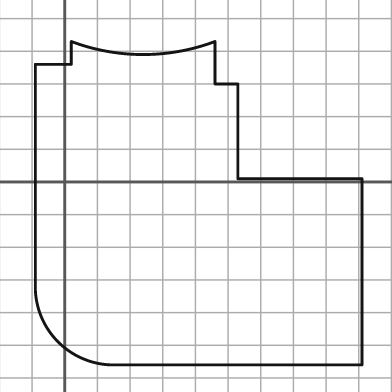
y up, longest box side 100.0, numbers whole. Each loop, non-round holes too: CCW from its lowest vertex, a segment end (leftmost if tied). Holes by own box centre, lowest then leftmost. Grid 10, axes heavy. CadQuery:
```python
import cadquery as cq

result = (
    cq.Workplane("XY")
    .moveTo(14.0, -56.0)
    .lineTo(91.0, -56.0)
    .lineTo(91.0, 1.0)
    .lineTo(53.0, 1.0)
    .lineTo(53.0, 30.0)
    .lineTo(46.0, 30.0)
    .lineTo(46.0, 43.0)
    .threePointArc((24.0, 39.0), (2.0, 43.0))
    .lineTo(2.0, 36.0)
    .lineTo(-9.0, 36.0)
    .lineTo(-9.0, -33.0)
    .threePointArc((-2.0, -49.0), (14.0, -56.0))
    .close()
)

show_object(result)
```